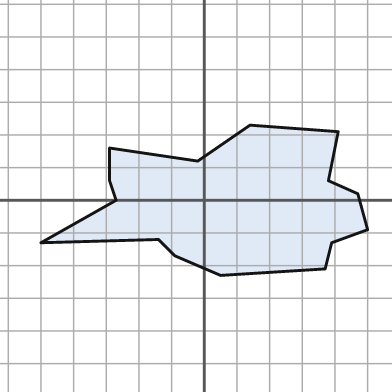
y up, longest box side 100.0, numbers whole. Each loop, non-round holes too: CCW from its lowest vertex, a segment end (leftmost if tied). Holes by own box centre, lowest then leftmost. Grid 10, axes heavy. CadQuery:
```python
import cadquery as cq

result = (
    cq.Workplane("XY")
    .moveTo(5.0, -23.0)
    .lineTo(37.0, -21.0)
    .lineTo(39.0, -13.0)
    .lineTo(50.0, -9.0)
    .lineTo(47.0, 2.0)
    .lineTo(38.0, 6.0)
    .lineTo(41.0, 21.0)
    .lineTo(14.0, 23.0)
    .lineTo(-2.0, 12.0)
    .lineTo(-29.0, 16.0)
    .lineTo(-29.0, 6.0)
    .lineTo(-27.0, 0.0)
    .lineTo(-50.0, -13.0)
    .lineTo(-14.0, -12.0)
    .lineTo(-9.0, -17.0)
    .close()
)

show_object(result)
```